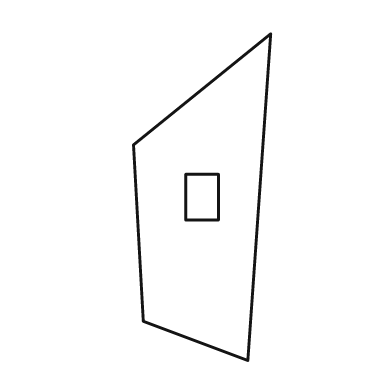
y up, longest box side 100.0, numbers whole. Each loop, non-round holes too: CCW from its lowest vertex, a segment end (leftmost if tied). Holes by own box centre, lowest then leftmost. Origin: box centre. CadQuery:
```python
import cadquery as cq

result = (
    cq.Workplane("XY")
    .moveTo(14.0, -50.0)
    .lineTo(21.0, 50.0)
    .lineTo(-21.0, 16.0)
    .lineTo(-18.0, -38.0)
    .close()
    .moveTo(-5.0, -7.0)
    .lineTo(5.0, -7.0)
    .lineTo(5.0, 7.0)
    .lineTo(-5.0, 7.0)
    .close()
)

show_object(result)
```